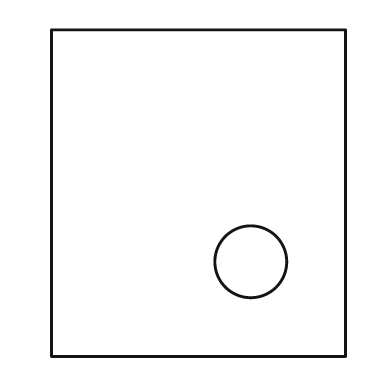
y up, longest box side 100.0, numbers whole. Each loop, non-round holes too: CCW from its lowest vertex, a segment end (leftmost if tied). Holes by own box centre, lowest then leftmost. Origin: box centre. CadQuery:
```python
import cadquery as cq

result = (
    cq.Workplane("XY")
    .moveTo(-45.0, -50.0)
    .lineTo(45.0, -50.0)
    .lineTo(45.0, 50.0)
    .lineTo(-45.0, 50.0)
    .close()
    .moveTo(16.0, -21.0)
    .circle(11.0)
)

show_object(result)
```